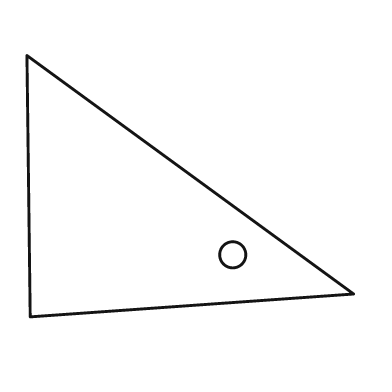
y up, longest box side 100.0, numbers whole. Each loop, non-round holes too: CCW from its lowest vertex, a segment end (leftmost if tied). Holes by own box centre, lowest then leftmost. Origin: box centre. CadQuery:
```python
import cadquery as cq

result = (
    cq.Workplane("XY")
    .moveTo(-49.0, -40.0)
    .lineTo(50.0, -33.0)
    .lineTo(-50.0, 40.0)
    .close()
    .moveTo(13.0, -21.0)
    .circle(4.0)
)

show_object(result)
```